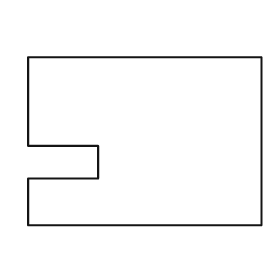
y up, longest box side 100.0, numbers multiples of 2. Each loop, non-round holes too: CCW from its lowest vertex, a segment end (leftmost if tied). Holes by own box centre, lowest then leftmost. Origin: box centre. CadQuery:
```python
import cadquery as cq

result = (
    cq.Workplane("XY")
    .moveTo(-50.0, -36.0)
    .lineTo(50.0, -36.0)
    .lineTo(50.0, 36.0)
    .lineTo(-50.0, 36.0)
    .lineTo(-50.0, -2.0)
    .lineTo(-20.0, -2.0)
    .lineTo(-20.0, -16.0)
    .lineTo(-50.0, -16.0)
    .close()
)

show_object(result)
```